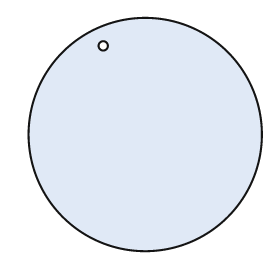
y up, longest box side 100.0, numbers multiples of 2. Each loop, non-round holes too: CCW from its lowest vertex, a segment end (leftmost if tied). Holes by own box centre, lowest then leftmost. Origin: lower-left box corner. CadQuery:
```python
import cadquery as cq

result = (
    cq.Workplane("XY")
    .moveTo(50.0, 50.0)
    .circle(50.0)
    .moveTo(32.0, 88.0)
    .circle(2.0)
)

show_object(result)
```